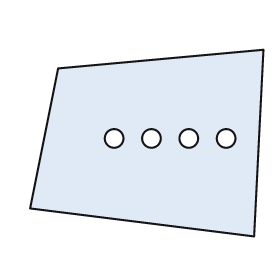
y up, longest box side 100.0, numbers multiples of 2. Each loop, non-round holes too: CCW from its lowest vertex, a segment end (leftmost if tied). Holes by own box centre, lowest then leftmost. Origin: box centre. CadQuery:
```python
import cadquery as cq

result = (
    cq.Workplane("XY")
    .moveTo(46.0, -40.0)
    .lineTo(50.0, 40.0)
    .lineTo(-38.0, 32.0)
    .lineTo(-50.0, -28.0)
    .close()
    .moveTo(-14.0, 2.0)
    .circle(4.0)
    .moveTo(2.0, 2.0)
    .circle(4.0)
    .moveTo(18.0, 2.0)
    .circle(4.0)
    .moveTo(34.0, 2.0)
    .circle(4.0)
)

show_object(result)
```